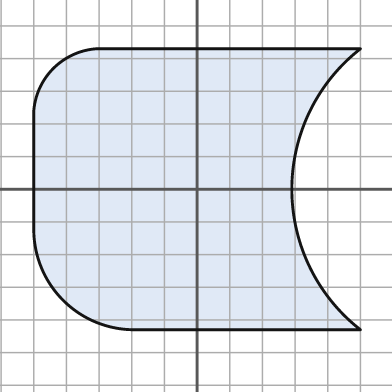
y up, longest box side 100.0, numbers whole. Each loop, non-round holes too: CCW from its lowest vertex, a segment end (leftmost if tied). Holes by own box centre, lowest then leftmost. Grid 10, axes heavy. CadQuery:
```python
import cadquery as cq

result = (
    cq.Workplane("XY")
    .moveTo(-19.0, -43.0)
    .lineTo(50.0, -43.0)
    .threePointArc((29.0, 0.0), (50.0, 43.0))
    .lineTo(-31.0, 43.0)
    .threePointArc((-44.0, 37.0), (-50.0, 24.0))
    .lineTo(-50.0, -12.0)
    .threePointArc((-41.0, -34.0), (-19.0, -43.0))
    .close()
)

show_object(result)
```